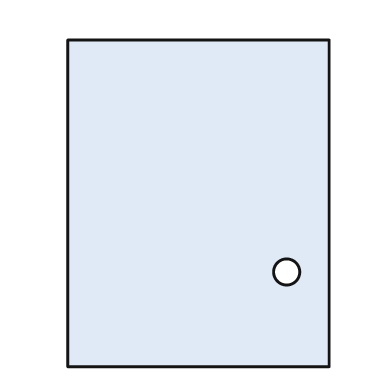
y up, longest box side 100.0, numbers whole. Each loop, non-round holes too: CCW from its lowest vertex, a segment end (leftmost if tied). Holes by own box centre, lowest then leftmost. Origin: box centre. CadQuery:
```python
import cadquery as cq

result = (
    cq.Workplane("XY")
    .moveTo(-40.0, -50.0)
    .lineTo(40.0, -50.0)
    .lineTo(40.0, 50.0)
    .lineTo(-40.0, 50.0)
    .close()
    .moveTo(27.0, -21.0)
    .circle(4.0)
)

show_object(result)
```